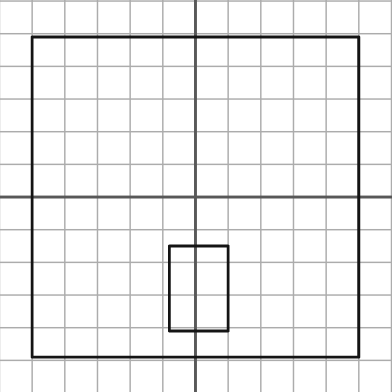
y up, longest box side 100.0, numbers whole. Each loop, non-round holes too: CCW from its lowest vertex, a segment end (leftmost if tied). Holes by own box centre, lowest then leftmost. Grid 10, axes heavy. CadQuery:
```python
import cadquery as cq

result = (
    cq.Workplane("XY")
    .moveTo(-50.0, -49.0)
    .lineTo(50.0, -49.0)
    .lineTo(50.0, 49.0)
    .lineTo(-50.0, 49.0)
    .close()
    .moveTo(-8.0, -41.0)
    .lineTo(10.0, -41.0)
    .lineTo(10.0, -15.0)
    .lineTo(-8.0, -15.0)
    .close()
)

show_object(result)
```